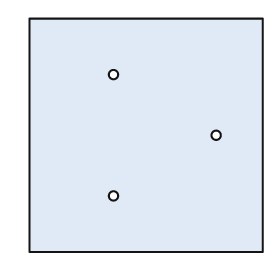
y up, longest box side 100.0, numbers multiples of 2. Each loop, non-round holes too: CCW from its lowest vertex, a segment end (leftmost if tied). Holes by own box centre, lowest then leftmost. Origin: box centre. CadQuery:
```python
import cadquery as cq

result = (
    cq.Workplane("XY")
    .moveTo(-50.0, -50.0)
    .lineTo(50.0, -50.0)
    .lineTo(50.0, 50.0)
    .lineTo(-50.0, 50.0)
    .close()
    .moveTo(-14.0, -26.0)
    .circle(2.0)
    .moveTo(30.0, 0.0)
    .circle(2.0)
    .moveTo(-14.0, 26.0)
    .circle(2.0)
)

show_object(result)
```